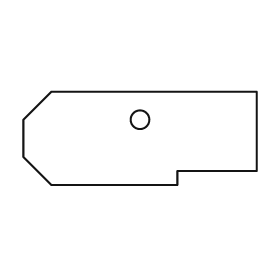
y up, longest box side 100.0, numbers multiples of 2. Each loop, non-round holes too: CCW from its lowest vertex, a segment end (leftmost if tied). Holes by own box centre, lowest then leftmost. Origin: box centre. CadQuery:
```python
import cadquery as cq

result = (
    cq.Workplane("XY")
    .moveTo(-38.0, -20.0)
    .lineTo(16.0, -20.0)
    .lineTo(16.0, -14.0)
    .lineTo(50.0, -14.0)
    .lineTo(50.0, 20.0)
    .lineTo(-38.0, 20.0)
    .lineTo(-50.0, 8.0)
    .lineTo(-50.0, -8.0)
    .close()
    .moveTo(0.0, 8.0)
    .circle(4.0)
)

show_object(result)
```